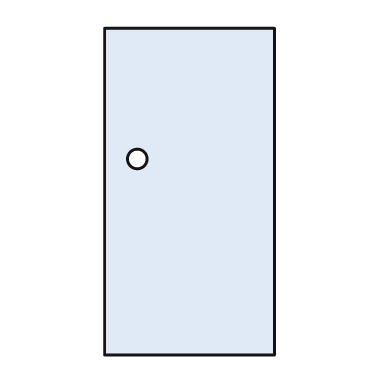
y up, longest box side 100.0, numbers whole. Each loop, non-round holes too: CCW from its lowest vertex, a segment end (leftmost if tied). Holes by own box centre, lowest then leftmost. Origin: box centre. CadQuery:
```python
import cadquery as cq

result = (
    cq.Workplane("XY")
    .moveTo(-26.0, -50.0)
    .lineTo(26.0, -50.0)
    .lineTo(26.0, 50.0)
    .lineTo(-26.0, 50.0)
    .close()
    .moveTo(-16.0, 10.0)
    .circle(3.0)
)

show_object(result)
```